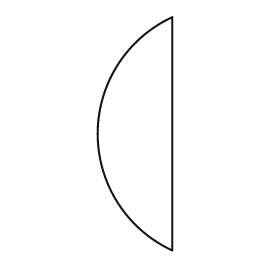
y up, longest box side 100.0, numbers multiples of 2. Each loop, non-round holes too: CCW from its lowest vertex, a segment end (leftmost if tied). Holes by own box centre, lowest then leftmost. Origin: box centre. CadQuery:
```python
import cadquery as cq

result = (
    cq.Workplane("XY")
    .moveTo(16.0, -50.0)
    .lineTo(16.0, 50.0)
    .threePointArc((-16.0, 0.0), (16.0, -50.0))
    .close()
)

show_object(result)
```